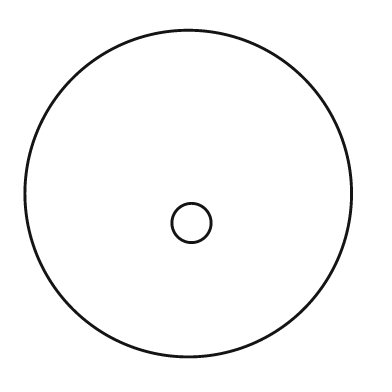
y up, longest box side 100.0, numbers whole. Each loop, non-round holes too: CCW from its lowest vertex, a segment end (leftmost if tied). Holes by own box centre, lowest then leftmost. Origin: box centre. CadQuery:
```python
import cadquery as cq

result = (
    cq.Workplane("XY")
    .moveTo(0.0, 0.0)
    .circle(50.0)
    .moveTo(1.0, -9.0)
    .circle(6.0)
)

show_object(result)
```